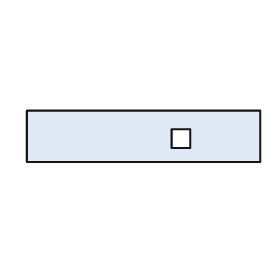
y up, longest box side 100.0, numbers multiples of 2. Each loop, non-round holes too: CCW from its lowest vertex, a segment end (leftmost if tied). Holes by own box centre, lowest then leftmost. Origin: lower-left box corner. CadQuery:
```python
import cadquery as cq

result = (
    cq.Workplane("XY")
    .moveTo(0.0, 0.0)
    .lineTo(100.0, 0.0)
    .lineTo(100.0, 22.0)
    .lineTo(0.0, 22.0)
    .close()
    .moveTo(62.0, 6.0)
    .lineTo(70.0, 6.0)
    .lineTo(70.0, 14.0)
    .lineTo(62.0, 14.0)
    .close()
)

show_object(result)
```